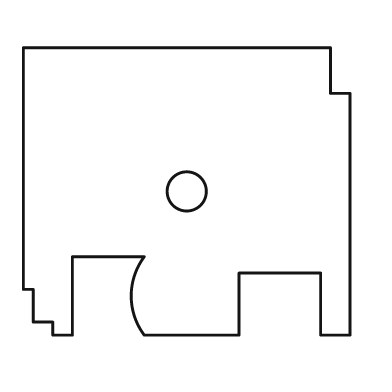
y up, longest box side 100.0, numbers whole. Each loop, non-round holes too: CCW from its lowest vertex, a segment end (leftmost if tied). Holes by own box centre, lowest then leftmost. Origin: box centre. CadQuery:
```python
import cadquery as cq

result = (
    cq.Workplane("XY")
    .moveTo(-41.0, -44.0)
    .lineTo(-35.0, -44.0)
    .lineTo(-35.0, -20.0)
    .lineTo(-13.0, -20.0)
    .threePointArc((-17.0, -32.0), (-13.0, -44.0))
    .lineTo(16.0, -44.0)
    .lineTo(16.0, -25.0)
    .lineTo(41.0, -25.0)
    .lineTo(41.0, -44.0)
    .lineTo(50.0, -44.0)
    .lineTo(50.0, 30.0)
    .lineTo(44.0, 30.0)
    .lineTo(44.0, 44.0)
    .lineTo(-50.0, 44.0)
    .lineTo(-50.0, -30.0)
    .lineTo(-47.0, -30.0)
    .lineTo(-47.0, -40.0)
    .lineTo(-41.0, -40.0)
    .close()
    .moveTo(0.0, 0.0)
    .circle(6.0)
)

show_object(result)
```